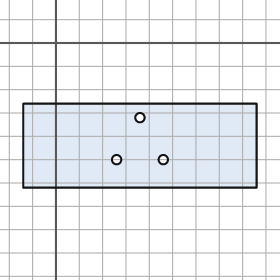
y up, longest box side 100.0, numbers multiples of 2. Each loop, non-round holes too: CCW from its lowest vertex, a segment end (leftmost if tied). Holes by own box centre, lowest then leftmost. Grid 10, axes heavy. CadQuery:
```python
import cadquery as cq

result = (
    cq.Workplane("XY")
    .moveTo(-14.0, -62.0)
    .lineTo(86.0, -62.0)
    .lineTo(86.0, -26.0)
    .lineTo(-14.0, -26.0)
    .close()
    .moveTo(26.0, -50.0)
    .circle(2.0)
    .moveTo(46.0, -50.0)
    .circle(2.0)
    .moveTo(36.0, -32.0)
    .circle(2.0)
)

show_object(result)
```